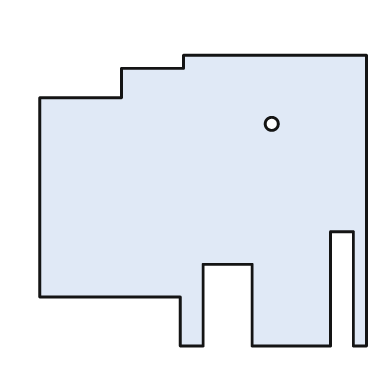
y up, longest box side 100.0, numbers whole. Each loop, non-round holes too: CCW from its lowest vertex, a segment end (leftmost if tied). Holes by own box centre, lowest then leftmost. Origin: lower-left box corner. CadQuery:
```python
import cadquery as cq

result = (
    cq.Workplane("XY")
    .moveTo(43.0, 0.0)
    .lineTo(50.0, 0.0)
    .lineTo(50.0, 25.0)
    .lineTo(65.0, 25.0)
    .lineTo(65.0, 0.0)
    .lineTo(89.0, 0.0)
    .lineTo(89.0, 35.0)
    .lineTo(96.0, 35.0)
    .lineTo(96.0, 0.0)
    .lineTo(100.0, 0.0)
    .lineTo(100.0, 89.0)
    .lineTo(44.0, 89.0)
    .lineTo(44.0, 85.0)
    .lineTo(25.0, 85.0)
    .lineTo(25.0, 76.0)
    .lineTo(0.0, 76.0)
    .lineTo(0.0, 15.0)
    .lineTo(43.0, 15.0)
    .close()
    .moveTo(71.0, 68.0)
    .circle(2.0)
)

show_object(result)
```